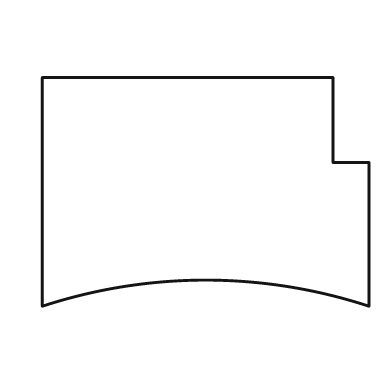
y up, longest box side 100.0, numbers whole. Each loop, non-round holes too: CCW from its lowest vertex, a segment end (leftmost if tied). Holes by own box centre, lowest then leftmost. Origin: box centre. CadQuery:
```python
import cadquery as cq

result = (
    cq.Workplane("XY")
    .moveTo(-50.0, -35.0)
    .threePointArc((0.0, -27.0), (50.0, -35.0))
    .lineTo(50.0, 9.0)
    .lineTo(39.0, 9.0)
    .lineTo(39.0, 35.0)
    .lineTo(-50.0, 35.0)
    .close()
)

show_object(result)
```